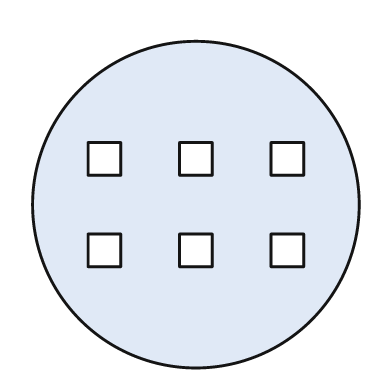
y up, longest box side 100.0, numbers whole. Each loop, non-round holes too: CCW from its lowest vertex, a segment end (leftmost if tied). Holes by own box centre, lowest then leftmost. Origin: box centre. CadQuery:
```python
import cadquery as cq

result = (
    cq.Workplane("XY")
    .moveTo(0.0, 0.0)
    .circle(50.0)
    .moveTo(-33.0, -19.0)
    .lineTo(-23.0, -19.0)
    .lineTo(-23.0, -9.0)
    .lineTo(-33.0, -9.0)
    .close()
    .moveTo(-5.0, -19.0)
    .lineTo(5.0, -19.0)
    .lineTo(5.0, -9.0)
    .lineTo(-5.0, -9.0)
    .close()
    .moveTo(23.0, -19.0)
    .lineTo(33.0, -19.0)
    .lineTo(33.0, -9.0)
    .lineTo(23.0, -9.0)
    .close()
    .moveTo(-33.0, 9.0)
    .lineTo(-23.0, 9.0)
    .lineTo(-23.0, 19.0)
    .lineTo(-33.0, 19.0)
    .close()
    .moveTo(-5.0, 9.0)
    .lineTo(5.0, 9.0)
    .lineTo(5.0, 19.0)
    .lineTo(-5.0, 19.0)
    .close()
    .moveTo(23.0, 9.0)
    .lineTo(33.0, 9.0)
    .lineTo(33.0, 19.0)
    .lineTo(23.0, 19.0)
    .close()
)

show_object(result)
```